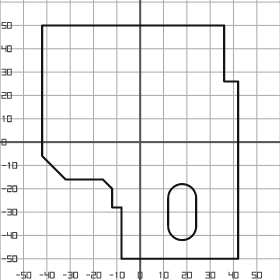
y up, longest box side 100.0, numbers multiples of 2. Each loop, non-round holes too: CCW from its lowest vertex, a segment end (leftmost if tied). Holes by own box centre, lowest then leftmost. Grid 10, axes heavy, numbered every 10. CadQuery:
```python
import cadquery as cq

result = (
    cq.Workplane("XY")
    .moveTo(-8.0, -50.0)
    .lineTo(42.0, -50.0)
    .lineTo(42.0, 26.0)
    .lineTo(36.0, 26.0)
    .lineTo(36.0, 50.0)
    .lineTo(-42.0, 50.0)
    .lineTo(-42.0, -6.0)
    .lineTo(-32.0, -16.0)
    .lineTo(-16.0, -16.0)
    .lineTo(-12.0, -20.0)
    .lineTo(-12.0, -28.0)
    .lineTo(-8.0, -28.0)
    .close()
    .moveTo(12.0, -36.0)
    .threePointArc((18.0, -42.0), (24.0, -36.0))
    .lineTo(24.0, -24.0)
    .threePointArc((18.0, -18.0), (12.0, -24.0))
    .close()
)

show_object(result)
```